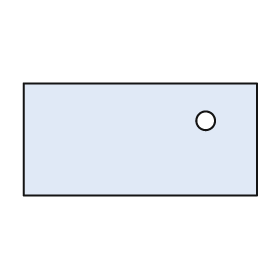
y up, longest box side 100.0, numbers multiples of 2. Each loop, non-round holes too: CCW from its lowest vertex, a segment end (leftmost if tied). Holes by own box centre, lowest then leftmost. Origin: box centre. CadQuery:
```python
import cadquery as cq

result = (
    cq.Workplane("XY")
    .moveTo(-50.0, -24.0)
    .lineTo(50.0, -24.0)
    .lineTo(50.0, 24.0)
    .lineTo(-50.0, 24.0)
    .close()
    .moveTo(28.0, 8.0)
    .circle(4.0)
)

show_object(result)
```